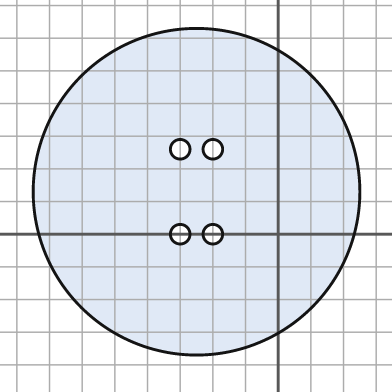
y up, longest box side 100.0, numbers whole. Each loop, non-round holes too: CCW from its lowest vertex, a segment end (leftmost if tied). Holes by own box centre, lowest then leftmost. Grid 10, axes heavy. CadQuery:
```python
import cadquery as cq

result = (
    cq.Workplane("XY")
    .moveTo(-25.0, 13.0)
    .circle(50.0)
    .moveTo(-30.0, 0.0)
    .circle(3.0)
    .moveTo(-20.0, 0.0)
    .circle(3.0)
    .moveTo(-30.0, 26.0)
    .circle(3.0)
    .moveTo(-20.0, 26.0)
    .circle(3.0)
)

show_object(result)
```